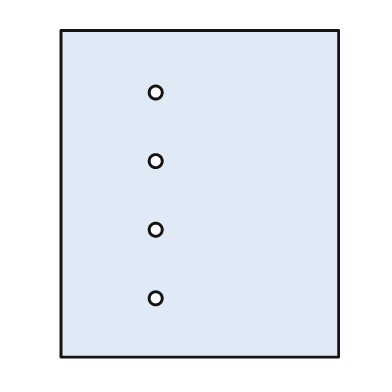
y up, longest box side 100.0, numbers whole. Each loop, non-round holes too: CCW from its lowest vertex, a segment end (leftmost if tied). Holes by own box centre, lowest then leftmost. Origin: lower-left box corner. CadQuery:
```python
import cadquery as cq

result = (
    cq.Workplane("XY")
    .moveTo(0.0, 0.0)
    .lineTo(85.0, 0.0)
    .lineTo(85.0, 100.0)
    .lineTo(0.0, 100.0)
    .close()
    .moveTo(29.0, 18.0)
    .circle(2.0)
    .moveTo(29.0, 39.0)
    .circle(2.0)
    .moveTo(29.0, 60.0)
    .circle(2.0)
    .moveTo(29.0, 81.0)
    .circle(2.0)
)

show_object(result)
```